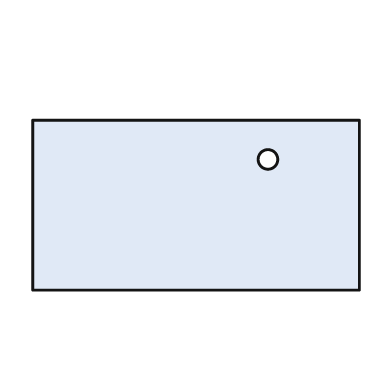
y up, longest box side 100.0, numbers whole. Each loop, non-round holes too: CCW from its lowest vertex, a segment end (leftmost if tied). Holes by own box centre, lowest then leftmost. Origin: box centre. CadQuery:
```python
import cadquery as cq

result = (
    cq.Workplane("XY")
    .moveTo(-50.0, -26.0)
    .lineTo(50.0, -26.0)
    .lineTo(50.0, 26.0)
    .lineTo(-50.0, 26.0)
    .close()
    .moveTo(22.0, 14.0)
    .circle(3.0)
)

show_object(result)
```